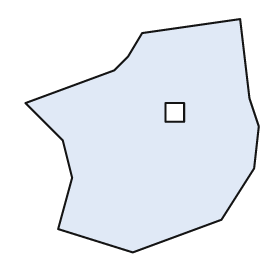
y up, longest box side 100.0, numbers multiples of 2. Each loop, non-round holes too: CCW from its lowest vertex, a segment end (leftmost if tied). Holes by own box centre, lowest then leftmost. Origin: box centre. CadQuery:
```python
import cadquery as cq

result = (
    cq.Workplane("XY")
    .moveTo(-4.0, -50.0)
    .lineTo(34.0, -36.0)
    .lineTo(48.0, -14.0)
    .lineTo(50.0, 4.0)
    .lineTo(46.0, 16.0)
    .lineTo(42.0, 50.0)
    .lineTo(0.0, 44.0)
    .lineTo(-6.0, 34.0)
    .lineTo(-12.0, 28.0)
    .lineTo(-50.0, 14.0)
    .lineTo(-34.0, -2.0)
    .lineTo(-30.0, -18.0)
    .lineTo(-36.0, -40.0)
    .close()
    .moveTo(10.0, 6.0)
    .lineTo(18.0, 6.0)
    .lineTo(18.0, 14.0)
    .lineTo(10.0, 14.0)
    .close()
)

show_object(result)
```